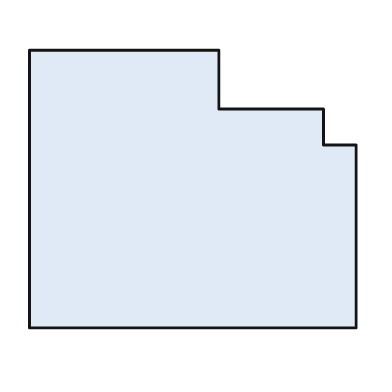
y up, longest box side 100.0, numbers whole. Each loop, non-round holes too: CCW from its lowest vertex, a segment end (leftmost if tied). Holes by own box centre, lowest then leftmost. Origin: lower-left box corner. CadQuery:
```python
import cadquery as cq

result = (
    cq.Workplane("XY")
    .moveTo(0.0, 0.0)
    .lineTo(100.0, 0.0)
    .lineTo(100.0, 56.0)
    .lineTo(90.0, 56.0)
    .lineTo(90.0, 67.0)
    .lineTo(58.0, 67.0)
    .lineTo(58.0, 85.0)
    .lineTo(0.0, 85.0)
    .close()
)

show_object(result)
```